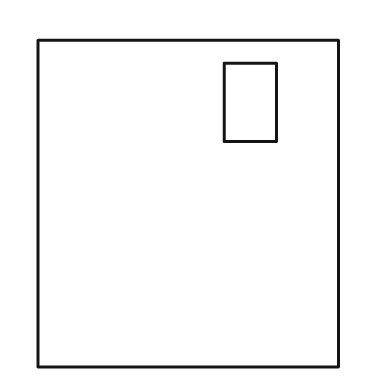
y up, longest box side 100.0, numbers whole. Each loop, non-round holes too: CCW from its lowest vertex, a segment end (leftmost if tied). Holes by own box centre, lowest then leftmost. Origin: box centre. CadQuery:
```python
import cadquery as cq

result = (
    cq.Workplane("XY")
    .moveTo(-46.0, -50.0)
    .lineTo(46.0, -50.0)
    .lineTo(46.0, 50.0)
    .lineTo(-46.0, 50.0)
    .close()
    .moveTo(11.0, 19.0)
    .lineTo(27.0, 19.0)
    .lineTo(27.0, 43.0)
    .lineTo(11.0, 43.0)
    .close()
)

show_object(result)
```